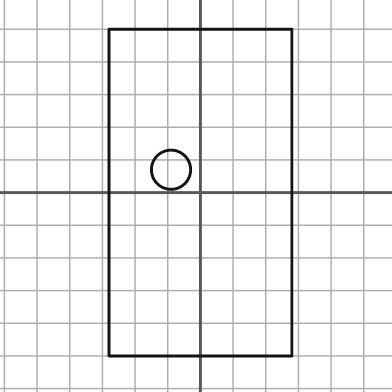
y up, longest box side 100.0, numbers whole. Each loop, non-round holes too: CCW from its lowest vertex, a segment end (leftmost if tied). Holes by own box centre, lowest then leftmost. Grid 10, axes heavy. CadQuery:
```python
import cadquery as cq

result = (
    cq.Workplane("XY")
    .moveTo(-28.0, -50.0)
    .lineTo(28.0, -50.0)
    .lineTo(28.0, 50.0)
    .lineTo(-28.0, 50.0)
    .close()
    .moveTo(-9.0, 7.0)
    .circle(6.0)
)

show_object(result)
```